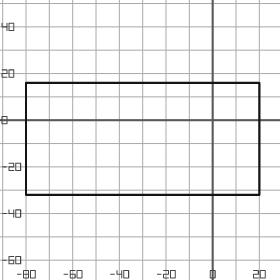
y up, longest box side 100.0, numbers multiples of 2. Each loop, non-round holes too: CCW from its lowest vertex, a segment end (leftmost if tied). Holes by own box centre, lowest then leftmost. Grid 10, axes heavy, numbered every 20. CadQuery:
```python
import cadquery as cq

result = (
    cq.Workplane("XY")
    .moveTo(-80.0, -32.0)
    .lineTo(20.0, -32.0)
    .lineTo(20.0, 16.0)
    .lineTo(-80.0, 16.0)
    .close()
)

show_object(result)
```